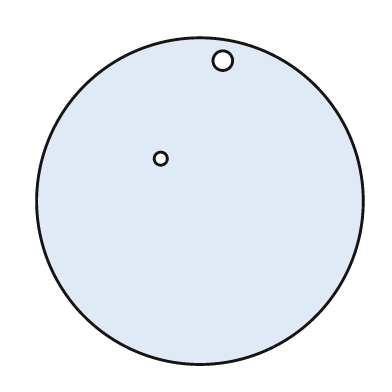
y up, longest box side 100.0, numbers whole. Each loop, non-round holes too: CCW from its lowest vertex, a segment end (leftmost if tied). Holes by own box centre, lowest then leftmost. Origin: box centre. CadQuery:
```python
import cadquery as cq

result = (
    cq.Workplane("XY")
    .moveTo(0.0, 0.0)
    .circle(50.0)
    .moveTo(-12.0, 13.0)
    .circle(2.0)
    .moveTo(7.0, 43.0)
    .circle(3.0)
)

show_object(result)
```